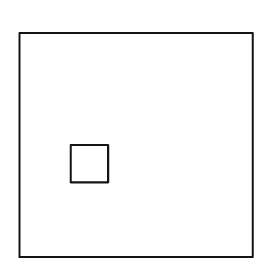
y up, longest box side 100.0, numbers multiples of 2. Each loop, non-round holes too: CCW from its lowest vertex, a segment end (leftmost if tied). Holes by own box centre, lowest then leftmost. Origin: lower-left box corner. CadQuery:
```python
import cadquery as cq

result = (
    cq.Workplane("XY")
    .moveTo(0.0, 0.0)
    .lineTo(100.0, 0.0)
    .lineTo(100.0, 96.0)
    .lineTo(0.0, 96.0)
    .close()
    .moveTo(22.0, 32.0)
    .lineTo(38.0, 32.0)
    .lineTo(38.0, 48.0)
    .lineTo(22.0, 48.0)
    .close()
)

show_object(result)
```